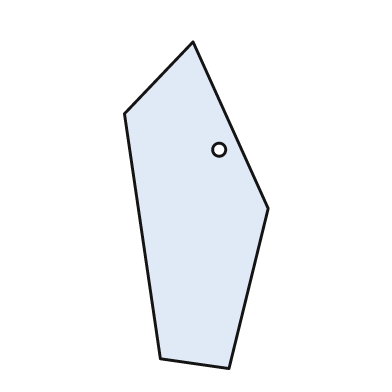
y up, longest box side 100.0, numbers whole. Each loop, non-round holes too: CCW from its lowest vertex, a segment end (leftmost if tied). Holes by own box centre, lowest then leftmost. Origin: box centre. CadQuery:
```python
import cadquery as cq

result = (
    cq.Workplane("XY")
    .moveTo(10.0, -50.0)
    .lineTo(22.0, -1.0)
    .lineTo(-1.0, 50.0)
    .lineTo(-22.0, 28.0)
    .lineTo(-11.0, -47.0)
    .close()
    .moveTo(7.0, 17.0)
    .circle(2.0)
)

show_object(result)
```